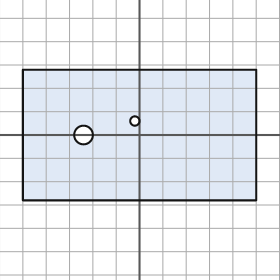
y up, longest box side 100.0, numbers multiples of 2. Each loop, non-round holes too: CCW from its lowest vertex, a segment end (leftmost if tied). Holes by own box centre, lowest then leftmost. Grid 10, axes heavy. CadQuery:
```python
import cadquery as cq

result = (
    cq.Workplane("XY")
    .moveTo(-50.0, -28.0)
    .lineTo(50.0, -28.0)
    .lineTo(50.0, 28.0)
    .lineTo(-50.0, 28.0)
    .close()
    .moveTo(-24.0, 0.0)
    .circle(4.0)
    .moveTo(-2.0, 6.0)
    .circle(2.0)
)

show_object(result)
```